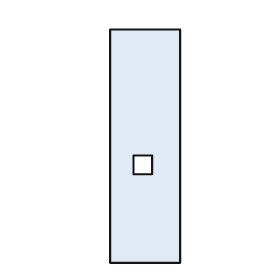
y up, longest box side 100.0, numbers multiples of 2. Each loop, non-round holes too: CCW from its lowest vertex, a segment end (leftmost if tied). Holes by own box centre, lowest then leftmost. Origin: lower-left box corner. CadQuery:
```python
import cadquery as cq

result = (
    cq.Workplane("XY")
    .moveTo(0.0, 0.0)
    .lineTo(30.0, 0.0)
    .lineTo(30.0, 100.0)
    .lineTo(0.0, 100.0)
    .close()
    .moveTo(10.0, 38.0)
    .lineTo(18.0, 38.0)
    .lineTo(18.0, 46.0)
    .lineTo(10.0, 46.0)
    .close()
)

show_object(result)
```